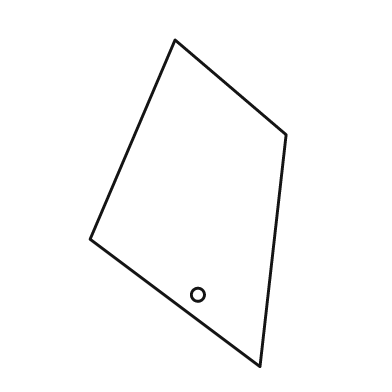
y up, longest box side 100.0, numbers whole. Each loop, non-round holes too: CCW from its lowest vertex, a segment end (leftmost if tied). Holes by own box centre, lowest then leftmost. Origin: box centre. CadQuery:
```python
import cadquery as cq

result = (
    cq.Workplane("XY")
    .moveTo(22.0, -50.0)
    .lineTo(30.0, 21.0)
    .lineTo(-4.0, 50.0)
    .lineTo(-30.0, -11.0)
    .close()
    .moveTo(3.0, -28.0)
    .circle(2.0)
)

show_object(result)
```